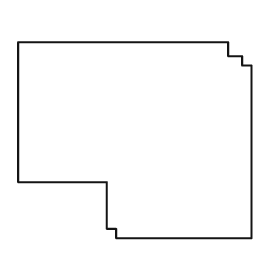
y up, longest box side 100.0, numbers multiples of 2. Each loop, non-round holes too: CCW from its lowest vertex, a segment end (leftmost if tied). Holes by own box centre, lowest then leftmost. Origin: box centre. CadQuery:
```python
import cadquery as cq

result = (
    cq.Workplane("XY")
    .moveTo(-8.0, -42.0)
    .lineTo(50.0, -42.0)
    .lineTo(50.0, 32.0)
    .lineTo(46.0, 32.0)
    .lineTo(46.0, 36.0)
    .lineTo(40.0, 36.0)
    .lineTo(40.0, 42.0)
    .lineTo(-50.0, 42.0)
    .lineTo(-50.0, -18.0)
    .lineTo(-12.0, -18.0)
    .lineTo(-12.0, -38.0)
    .lineTo(-8.0, -38.0)
    .close()
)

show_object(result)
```